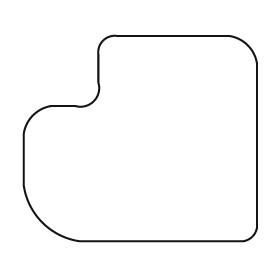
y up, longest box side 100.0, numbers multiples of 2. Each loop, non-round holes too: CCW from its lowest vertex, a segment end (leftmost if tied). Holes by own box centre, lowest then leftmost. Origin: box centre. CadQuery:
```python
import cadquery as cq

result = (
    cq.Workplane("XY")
    .moveTo(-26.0, -44.0)
    .lineTo(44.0, -44.0)
    .threePointArc((48.0, -42.0), (50.0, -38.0))
    .lineTo(50.0, 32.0)
    .threePointArc((46.0, 40.0), (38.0, 44.0))
    .lineTo(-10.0, 44.0)
    .threePointArc((-16.0, 42.0), (-18.0, 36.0))
    .lineTo(-18.0, 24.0)
    .threePointArc((-20.0, 16.0), (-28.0, 14.0))
    .lineTo(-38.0, 14.0)
    .threePointArc((-46.0, 10.0), (-50.0, 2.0))
    .lineTo(-50.0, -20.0)
    .threePointArc((-42.0, -36.0), (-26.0, -44.0))
    .close()
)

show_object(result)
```